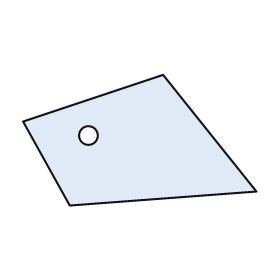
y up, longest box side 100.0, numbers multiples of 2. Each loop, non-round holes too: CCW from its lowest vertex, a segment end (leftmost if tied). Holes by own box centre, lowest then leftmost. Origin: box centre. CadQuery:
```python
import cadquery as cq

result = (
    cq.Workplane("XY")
    .moveTo(-30.0, -28.0)
    .lineTo(50.0, -22.0)
    .lineTo(10.0, 28.0)
    .lineTo(-50.0, 8.0)
    .close()
    .moveTo(-22.0, 2.0)
    .circle(4.0)
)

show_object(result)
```